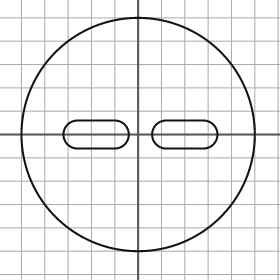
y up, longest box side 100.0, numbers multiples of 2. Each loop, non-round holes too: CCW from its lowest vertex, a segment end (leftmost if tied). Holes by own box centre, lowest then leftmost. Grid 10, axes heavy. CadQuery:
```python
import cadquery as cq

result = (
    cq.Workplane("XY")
    .moveTo(0.0, 0.0)
    .circle(50.0)
    .moveTo(-26.0, -6.0)
    .lineTo(-10.0, -6.0)
    .threePointArc((-4.0, 0.0), (-10.0, 6.0))
    .lineTo(-26.0, 6.0)
    .threePointArc((-32.0, 0.0), (-26.0, -6.0))
    .close()
    .moveTo(12.0, -6.0)
    .lineTo(28.0, -6.0)
    .threePointArc((34.0, 0.0), (28.0, 6.0))
    .lineTo(12.0, 6.0)
    .threePointArc((6.0, 0.0), (12.0, -6.0))
    .close()
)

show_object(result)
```